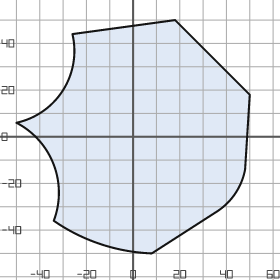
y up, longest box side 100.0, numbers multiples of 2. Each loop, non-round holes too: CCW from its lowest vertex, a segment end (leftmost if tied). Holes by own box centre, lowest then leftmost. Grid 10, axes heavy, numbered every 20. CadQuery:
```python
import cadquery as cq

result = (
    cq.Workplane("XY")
    .moveTo(8.0, -50.0)
    .lineTo(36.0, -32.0)
    .threePointArc((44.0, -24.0), (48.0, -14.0))
    .lineTo(50.0, 18.0)
    .lineTo(18.0, 50.0)
    .lineTo(-26.0, 44.0)
    .threePointArc((-30.0, 20.0), (-50.0, 6.0))
    .threePointArc((-34.0, -12.0), (-34.0, -36.0))
    .threePointArc((-14.0, -46.0), (8.0, -50.0))
    .close()
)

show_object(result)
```